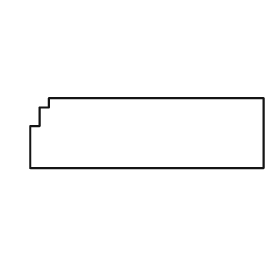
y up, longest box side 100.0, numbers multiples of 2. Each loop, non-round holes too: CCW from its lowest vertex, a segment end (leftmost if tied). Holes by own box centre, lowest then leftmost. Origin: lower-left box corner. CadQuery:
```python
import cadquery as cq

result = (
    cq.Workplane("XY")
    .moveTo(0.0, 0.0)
    .lineTo(100.0, 0.0)
    .lineTo(100.0, 30.0)
    .lineTo(8.0, 30.0)
    .lineTo(8.0, 26.0)
    .lineTo(4.0, 26.0)
    .lineTo(4.0, 18.0)
    .lineTo(0.0, 18.0)
    .close()
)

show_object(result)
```